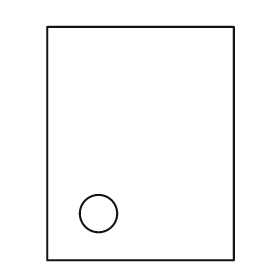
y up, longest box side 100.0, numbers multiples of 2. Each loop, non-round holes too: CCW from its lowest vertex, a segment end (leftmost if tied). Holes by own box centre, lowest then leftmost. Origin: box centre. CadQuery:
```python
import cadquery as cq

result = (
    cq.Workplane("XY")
    .moveTo(-40.0, -50.0)
    .lineTo(40.0, -50.0)
    .lineTo(40.0, 50.0)
    .lineTo(-40.0, 50.0)
    .close()
    .moveTo(-18.0, -30.0)
    .circle(8.0)
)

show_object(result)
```